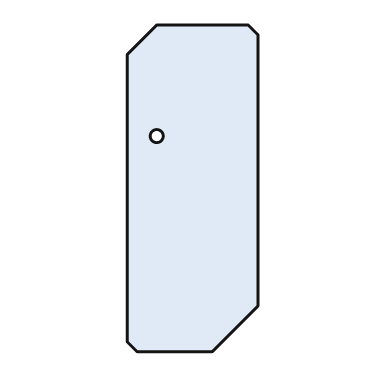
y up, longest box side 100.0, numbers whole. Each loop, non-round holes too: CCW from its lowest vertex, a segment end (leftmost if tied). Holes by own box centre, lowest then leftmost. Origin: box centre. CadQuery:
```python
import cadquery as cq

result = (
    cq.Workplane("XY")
    .moveTo(-17.0, -50.0)
    .lineTo(6.0, -50.0)
    .lineTo(20.0, -36.0)
    .lineTo(20.0, 47.0)
    .lineTo(17.0, 50.0)
    .lineTo(-11.0, 50.0)
    .lineTo(-20.0, 41.0)
    .lineTo(-20.0, -47.0)
    .close()
    .moveTo(-11.0, 16.0)
    .circle(2.0)
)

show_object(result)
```